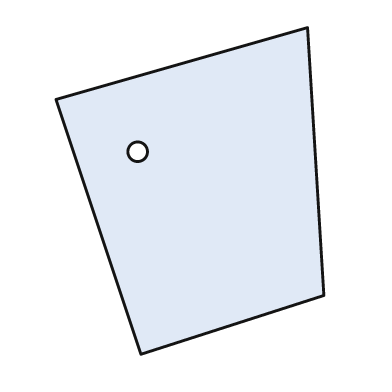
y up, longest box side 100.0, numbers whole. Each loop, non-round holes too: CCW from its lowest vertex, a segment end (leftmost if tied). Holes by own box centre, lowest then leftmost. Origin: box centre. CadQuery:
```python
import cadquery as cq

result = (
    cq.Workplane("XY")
    .moveTo(-15.0, -50.0)
    .lineTo(41.0, -32.0)
    .lineTo(36.0, 50.0)
    .lineTo(-41.0, 28.0)
    .close()
    .moveTo(-16.0, 12.0)
    .circle(3.0)
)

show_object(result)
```